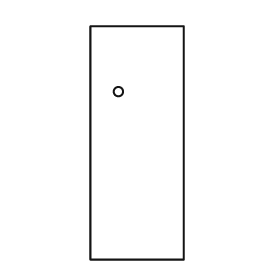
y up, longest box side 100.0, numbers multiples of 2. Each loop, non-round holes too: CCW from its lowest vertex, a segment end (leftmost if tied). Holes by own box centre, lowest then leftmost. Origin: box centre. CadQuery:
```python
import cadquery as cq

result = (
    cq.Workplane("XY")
    .moveTo(-20.0, -50.0)
    .lineTo(20.0, -50.0)
    .lineTo(20.0, 50.0)
    .lineTo(-20.0, 50.0)
    .close()
    .moveTo(-8.0, 22.0)
    .circle(2.0)
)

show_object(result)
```